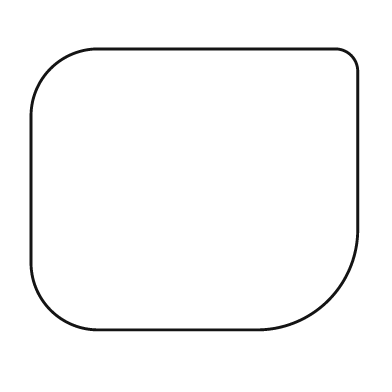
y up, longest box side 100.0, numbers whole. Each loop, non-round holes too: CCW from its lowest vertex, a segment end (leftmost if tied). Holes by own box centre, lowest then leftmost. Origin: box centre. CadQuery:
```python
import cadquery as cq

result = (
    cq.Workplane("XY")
    .moveTo(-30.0, -43.0)
    .lineTo(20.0, -43.0)
    .threePointArc((41.0, -34.0), (50.0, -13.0))
    .lineTo(50.0, 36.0)
    .threePointArc((48.0, 41.0), (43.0, 43.0))
    .lineTo(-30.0, 43.0)
    .threePointArc((-44.0, 37.0), (-50.0, 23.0))
    .lineTo(-50.0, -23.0)
    .threePointArc((-44.0, -37.0), (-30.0, -43.0))
    .close()
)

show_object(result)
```